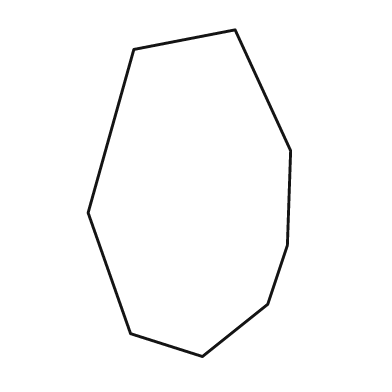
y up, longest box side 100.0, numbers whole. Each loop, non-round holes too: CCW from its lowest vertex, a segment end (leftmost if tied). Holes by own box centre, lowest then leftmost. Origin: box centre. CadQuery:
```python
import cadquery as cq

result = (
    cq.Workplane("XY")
    .moveTo(4.0, -50.0)
    .lineTo(24.0, -34.0)
    .lineTo(30.0, -16.0)
    .lineTo(31.0, 13.0)
    .lineTo(14.0, 50.0)
    .lineTo(-17.0, 44.0)
    .lineTo(-31.0, -6.0)
    .lineTo(-18.0, -43.0)
    .close()
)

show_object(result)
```